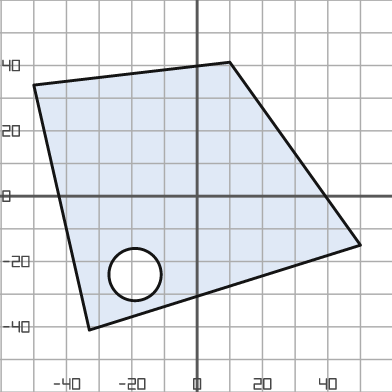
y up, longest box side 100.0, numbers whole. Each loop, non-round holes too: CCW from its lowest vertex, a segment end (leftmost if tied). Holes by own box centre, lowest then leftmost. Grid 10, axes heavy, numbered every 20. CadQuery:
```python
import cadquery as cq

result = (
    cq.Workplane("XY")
    .moveTo(-33.0, -41.0)
    .lineTo(50.0, -15.0)
    .lineTo(10.0, 41.0)
    .lineTo(-50.0, 34.0)
    .close()
    .moveTo(-19.0, -24.0)
    .circle(8.0)
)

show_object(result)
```